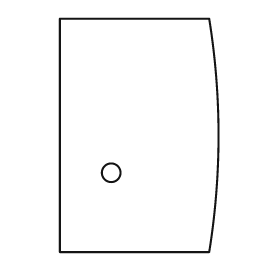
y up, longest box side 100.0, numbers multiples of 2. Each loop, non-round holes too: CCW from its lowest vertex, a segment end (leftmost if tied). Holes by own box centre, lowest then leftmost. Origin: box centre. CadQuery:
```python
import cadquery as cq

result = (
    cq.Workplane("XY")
    .moveTo(-34.0, -50.0)
    .lineTo(30.0, -50.0)
    .threePointArc((34.0, 0.0), (30.0, 50.0))
    .lineTo(-34.0, 50.0)
    .close()
    .moveTo(-12.0, -16.0)
    .circle(4.0)
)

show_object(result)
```